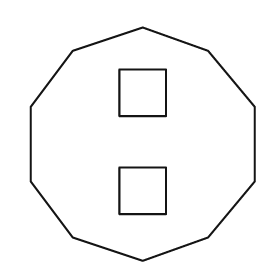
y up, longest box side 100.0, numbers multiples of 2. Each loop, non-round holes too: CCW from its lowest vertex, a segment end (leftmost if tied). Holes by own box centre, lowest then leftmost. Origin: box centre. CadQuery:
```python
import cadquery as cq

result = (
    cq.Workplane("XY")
    .moveTo(0.0, -50.0)
    .lineTo(28.0, -40.0)
    .lineTo(48.0, -16.0)
    .lineTo(48.0, 16.0)
    .lineTo(28.0, 40.0)
    .lineTo(0.0, 50.0)
    .lineTo(-30.0, 40.0)
    .lineTo(-48.0, 16.0)
    .lineTo(-48.0, -16.0)
    .lineTo(-30.0, -40.0)
    .close()
    .moveTo(-10.0, -30.0)
    .lineTo(10.0, -30.0)
    .lineTo(10.0, -10.0)
    .lineTo(-10.0, -10.0)
    .close()
    .moveTo(-10.0, 12.0)
    .lineTo(10.0, 12.0)
    .lineTo(10.0, 32.0)
    .lineTo(-10.0, 32.0)
    .close()
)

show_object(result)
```